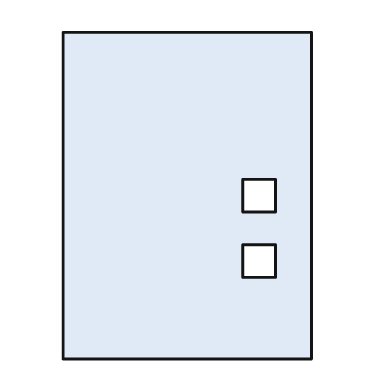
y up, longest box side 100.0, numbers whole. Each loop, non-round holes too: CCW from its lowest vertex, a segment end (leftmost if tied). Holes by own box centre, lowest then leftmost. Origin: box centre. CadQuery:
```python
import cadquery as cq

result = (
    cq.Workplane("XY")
    .moveTo(-38.0, -50.0)
    .lineTo(38.0, -50.0)
    .lineTo(38.0, 50.0)
    .lineTo(-38.0, 50.0)
    .close()
    .moveTo(17.0, -25.0)
    .lineTo(27.0, -25.0)
    .lineTo(27.0, -15.0)
    .lineTo(17.0, -15.0)
    .close()
    .moveTo(17.0, -5.0)
    .lineTo(27.0, -5.0)
    .lineTo(27.0, 5.0)
    .lineTo(17.0, 5.0)
    .close()
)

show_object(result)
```